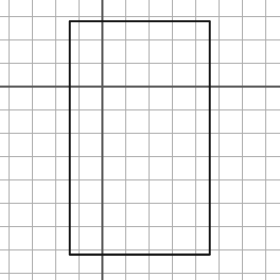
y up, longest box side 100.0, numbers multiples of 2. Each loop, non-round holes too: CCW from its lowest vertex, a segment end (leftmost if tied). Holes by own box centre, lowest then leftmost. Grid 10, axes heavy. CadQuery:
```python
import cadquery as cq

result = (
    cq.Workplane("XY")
    .moveTo(-14.0, -72.0)
    .lineTo(46.0, -72.0)
    .lineTo(46.0, 28.0)
    .lineTo(-14.0, 28.0)
    .close()
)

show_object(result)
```